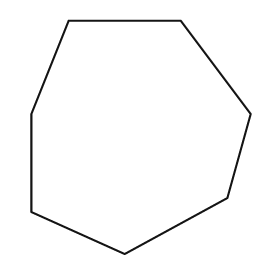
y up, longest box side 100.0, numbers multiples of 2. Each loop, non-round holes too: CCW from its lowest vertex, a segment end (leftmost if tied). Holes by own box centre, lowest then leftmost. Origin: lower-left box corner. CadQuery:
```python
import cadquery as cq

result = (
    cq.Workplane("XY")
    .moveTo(40.0, 0.0)
    .lineTo(84.0, 24.0)
    .lineTo(94.0, 60.0)
    .lineTo(64.0, 100.0)
    .lineTo(16.0, 100.0)
    .lineTo(0.0, 60.0)
    .lineTo(0.0, 18.0)
    .close()
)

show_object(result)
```